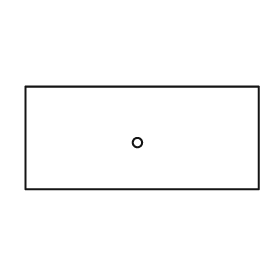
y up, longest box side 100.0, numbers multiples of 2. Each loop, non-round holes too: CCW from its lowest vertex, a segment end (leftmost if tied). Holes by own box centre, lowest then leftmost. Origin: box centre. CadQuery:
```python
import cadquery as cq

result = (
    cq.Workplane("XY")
    .moveTo(-50.0, -22.0)
    .lineTo(50.0, -22.0)
    .lineTo(50.0, 22.0)
    .lineTo(-50.0, 22.0)
    .close()
    .moveTo(-2.0, -2.0)
    .circle(2.0)
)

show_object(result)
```